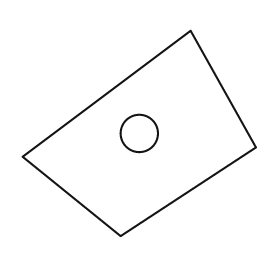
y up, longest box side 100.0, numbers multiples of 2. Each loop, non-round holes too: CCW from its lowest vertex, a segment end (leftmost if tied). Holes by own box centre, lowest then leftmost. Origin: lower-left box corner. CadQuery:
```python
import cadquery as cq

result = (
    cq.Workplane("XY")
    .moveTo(42.0, 0.0)
    .lineTo(100.0, 38.0)
    .lineTo(72.0, 88.0)
    .lineTo(0.0, 34.0)
    .close()
    .moveTo(50.0, 44.0)
    .circle(8.0)
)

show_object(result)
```